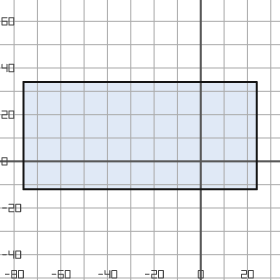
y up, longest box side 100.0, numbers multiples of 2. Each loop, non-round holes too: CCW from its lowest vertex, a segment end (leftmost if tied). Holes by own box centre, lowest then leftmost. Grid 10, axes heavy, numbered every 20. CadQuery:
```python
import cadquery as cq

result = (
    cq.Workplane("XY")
    .moveTo(-76.0, -12.0)
    .lineTo(24.0, -12.0)
    .lineTo(24.0, 34.0)
    .lineTo(-76.0, 34.0)
    .close()
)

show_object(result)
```